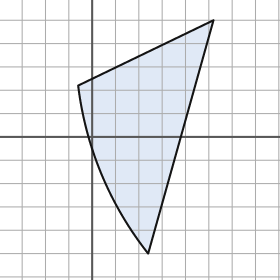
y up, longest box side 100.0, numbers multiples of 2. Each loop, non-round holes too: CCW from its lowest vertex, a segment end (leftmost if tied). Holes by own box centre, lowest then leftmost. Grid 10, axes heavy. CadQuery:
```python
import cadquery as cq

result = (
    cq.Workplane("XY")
    .moveTo(24.0, -50.0)
    .lineTo(52.0, 50.0)
    .lineTo(-6.0, 22.0)
    .threePointArc((4.0, -16.0), (24.0, -50.0))
    .close()
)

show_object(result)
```